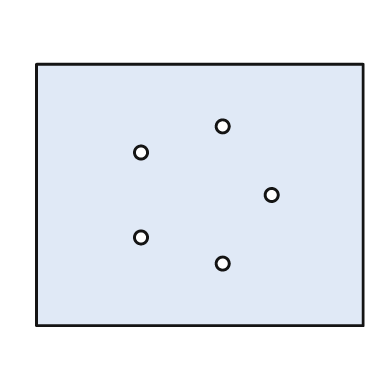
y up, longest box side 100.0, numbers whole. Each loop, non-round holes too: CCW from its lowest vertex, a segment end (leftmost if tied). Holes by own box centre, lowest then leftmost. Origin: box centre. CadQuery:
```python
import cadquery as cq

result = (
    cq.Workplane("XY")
    .moveTo(-50.0, -40.0)
    .lineTo(50.0, -40.0)
    .lineTo(50.0, 40.0)
    .lineTo(-50.0, 40.0)
    .close()
    .moveTo(7.0, -21.0)
    .circle(2.0)
    .moveTo(-18.0, -13.0)
    .circle(2.0)
    .moveTo(22.0, 0.0)
    .circle(2.0)
    .moveTo(-18.0, 13.0)
    .circle(2.0)
    .moveTo(7.0, 21.0)
    .circle(2.0)
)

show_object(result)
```